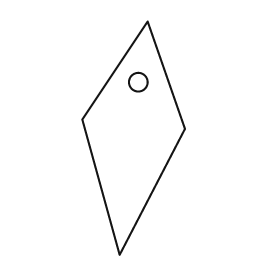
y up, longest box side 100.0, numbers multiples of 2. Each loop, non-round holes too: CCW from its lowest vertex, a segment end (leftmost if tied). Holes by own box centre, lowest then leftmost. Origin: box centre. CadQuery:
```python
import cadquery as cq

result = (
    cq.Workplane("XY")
    .moveTo(-6.0, -50.0)
    .lineTo(22.0, 4.0)
    .lineTo(6.0, 50.0)
    .lineTo(-22.0, 8.0)
    .close()
    .moveTo(2.0, 24.0)
    .circle(4.0)
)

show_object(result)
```